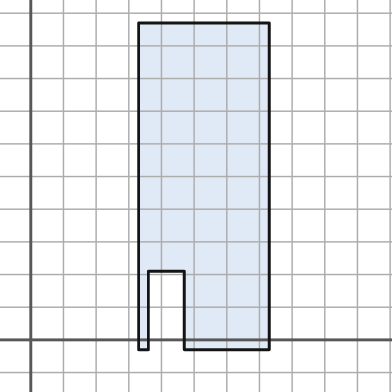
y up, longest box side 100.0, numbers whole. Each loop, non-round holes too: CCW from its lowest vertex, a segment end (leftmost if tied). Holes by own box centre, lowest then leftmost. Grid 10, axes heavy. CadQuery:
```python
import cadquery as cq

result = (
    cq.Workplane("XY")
    .moveTo(33.0, -3.0)
    .lineTo(36.0, -3.0)
    .lineTo(36.0, 21.0)
    .lineTo(47.0, 21.0)
    .lineTo(47.0, -3.0)
    .lineTo(73.0, -3.0)
    .lineTo(73.0, 97.0)
    .lineTo(33.0, 97.0)
    .close()
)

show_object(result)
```